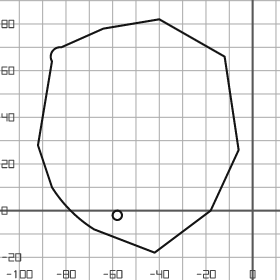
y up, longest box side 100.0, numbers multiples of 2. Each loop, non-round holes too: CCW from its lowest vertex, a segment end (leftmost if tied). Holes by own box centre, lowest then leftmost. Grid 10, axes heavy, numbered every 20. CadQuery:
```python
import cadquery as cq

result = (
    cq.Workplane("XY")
    .moveTo(-42.0, -18.0)
    .lineTo(-18.0, 0.0)
    .lineTo(-6.0, 26.0)
    .lineTo(-12.0, 66.0)
    .lineTo(-40.0, 82.0)
    .lineTo(-64.0, 78.0)
    .lineTo(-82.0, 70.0)
    .threePointArc((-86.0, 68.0), (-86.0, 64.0))
    .lineTo(-92.0, 28.0)
    .lineTo(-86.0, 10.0)
    .threePointArc((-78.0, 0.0), (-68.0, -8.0))
    .close()
    .moveTo(-58.0, -2.0)
    .circle(2.0)
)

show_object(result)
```